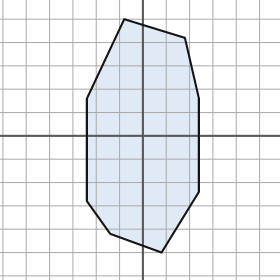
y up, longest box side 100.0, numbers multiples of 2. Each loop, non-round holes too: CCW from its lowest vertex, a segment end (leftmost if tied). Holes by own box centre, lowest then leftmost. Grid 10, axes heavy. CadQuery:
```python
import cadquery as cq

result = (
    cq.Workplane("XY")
    .moveTo(8.0, -50.0)
    .lineTo(24.0, -24.0)
    .lineTo(24.0, 16.0)
    .lineTo(18.0, 42.0)
    .lineTo(-8.0, 50.0)
    .lineTo(-24.0, 16.0)
    .lineTo(-24.0, -28.0)
    .lineTo(-14.0, -42.0)
    .close()
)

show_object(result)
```